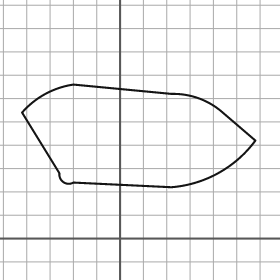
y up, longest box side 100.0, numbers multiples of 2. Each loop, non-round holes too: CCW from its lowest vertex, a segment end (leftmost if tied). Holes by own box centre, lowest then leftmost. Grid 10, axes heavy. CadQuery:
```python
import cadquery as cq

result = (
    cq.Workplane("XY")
    .moveTo(22.0, 22.0)
    .threePointArc((42.0, 28.0), (58.0, 42.0))
    .lineTo(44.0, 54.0)
    .threePointArc((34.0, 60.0), (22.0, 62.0))
    .lineTo(-20.0, 66.0)
    .threePointArc((-32.0, 62.0), (-42.0, 54.0))
    .lineTo(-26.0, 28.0)
    .threePointArc((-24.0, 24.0), (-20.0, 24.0))
    .close()
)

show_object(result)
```